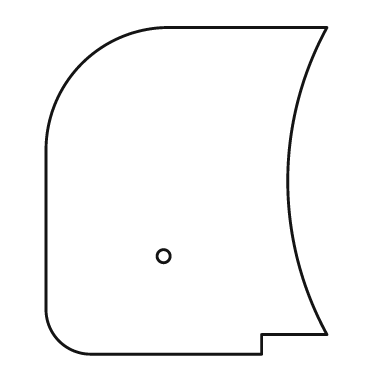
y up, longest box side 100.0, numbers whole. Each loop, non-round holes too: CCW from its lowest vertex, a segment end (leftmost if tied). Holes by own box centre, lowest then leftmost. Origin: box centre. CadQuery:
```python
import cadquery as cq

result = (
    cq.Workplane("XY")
    .moveTo(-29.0, -50.0)
    .lineTo(23.0, -50.0)
    .lineTo(23.0, -44.0)
    .lineTo(43.0, -44.0)
    .threePointArc((31.0, 3.0), (43.0, 50.0))
    .lineTo(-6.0, 50.0)
    .threePointArc((-32.0, 39.0), (-43.0, 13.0))
    .lineTo(-43.0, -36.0)
    .threePointArc((-39.0, -46.0), (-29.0, -50.0))
    .close()
    .moveTo(-7.0, -20.0)
    .circle(2.0)
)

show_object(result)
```